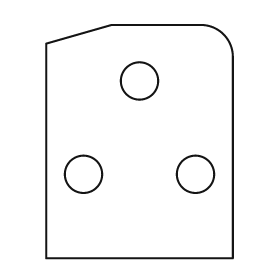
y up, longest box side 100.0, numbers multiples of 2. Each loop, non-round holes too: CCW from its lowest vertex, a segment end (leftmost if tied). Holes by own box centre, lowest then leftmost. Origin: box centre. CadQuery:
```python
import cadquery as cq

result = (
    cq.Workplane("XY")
    .moveTo(-40.0, -50.0)
    .lineTo(40.0, -50.0)
    .lineTo(40.0, 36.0)
    .threePointArc((36.0, 46.0), (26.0, 50.0))
    .lineTo(-12.0, 50.0)
    .lineTo(-40.0, 42.0)
    .close()
    .moveTo(-24.0, -14.0)
    .circle(8.0)
    .moveTo(24.0, -14.0)
    .circle(8.0)
    .moveTo(0.0, 26.0)
    .circle(8.0)
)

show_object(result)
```